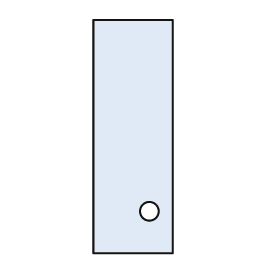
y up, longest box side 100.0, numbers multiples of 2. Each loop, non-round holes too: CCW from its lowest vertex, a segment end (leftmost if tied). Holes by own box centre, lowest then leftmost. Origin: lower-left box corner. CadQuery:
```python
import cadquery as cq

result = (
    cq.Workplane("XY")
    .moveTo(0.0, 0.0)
    .lineTo(34.0, 0.0)
    .lineTo(34.0, 100.0)
    .lineTo(0.0, 100.0)
    .close()
    .moveTo(24.0, 18.0)
    .circle(4.0)
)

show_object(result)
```